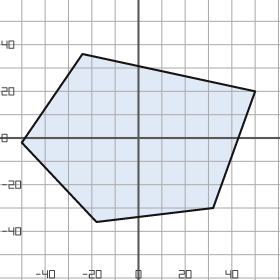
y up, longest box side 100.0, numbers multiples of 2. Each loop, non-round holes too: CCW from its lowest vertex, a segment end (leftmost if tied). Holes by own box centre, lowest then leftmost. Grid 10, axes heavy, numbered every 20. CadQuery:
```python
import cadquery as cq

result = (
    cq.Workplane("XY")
    .moveTo(-18.0, -36.0)
    .lineTo(32.0, -30.0)
    .lineTo(50.0, 20.0)
    .lineTo(-24.0, 36.0)
    .lineTo(-50.0, -2.0)
    .close()
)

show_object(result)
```